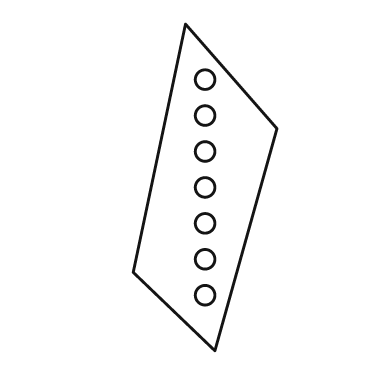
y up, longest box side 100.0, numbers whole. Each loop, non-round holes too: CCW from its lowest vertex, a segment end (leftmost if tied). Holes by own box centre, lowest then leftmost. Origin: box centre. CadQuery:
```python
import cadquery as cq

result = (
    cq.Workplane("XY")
    .moveTo(3.0, -50.0)
    .lineTo(22.0, 18.0)
    .lineTo(-6.0, 50.0)
    .lineTo(-22.0, -26.0)
    .close()
    .moveTo(0.0, -33.0)
    .circle(3.0)
    .moveTo(0.0, -22.0)
    .circle(3.0)
    .moveTo(0.0, -11.0)
    .circle(3.0)
    .moveTo(0.0, 0.0)
    .circle(3.0)
    .moveTo(0.0, 11.0)
    .circle(3.0)
    .moveTo(0.0, 22.0)
    .circle(3.0)
    .moveTo(0.0, 33.0)
    .circle(3.0)
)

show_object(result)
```